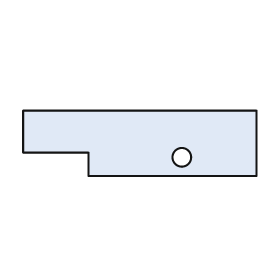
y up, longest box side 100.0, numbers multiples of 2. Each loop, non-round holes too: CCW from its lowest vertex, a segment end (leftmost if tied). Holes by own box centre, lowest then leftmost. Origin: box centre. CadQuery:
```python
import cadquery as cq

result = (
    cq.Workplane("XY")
    .moveTo(-22.0, -14.0)
    .lineTo(50.0, -14.0)
    .lineTo(50.0, 14.0)
    .lineTo(-50.0, 14.0)
    .lineTo(-50.0, -4.0)
    .lineTo(-22.0, -4.0)
    .close()
    .moveTo(18.0, -6.0)
    .circle(4.0)
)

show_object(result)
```